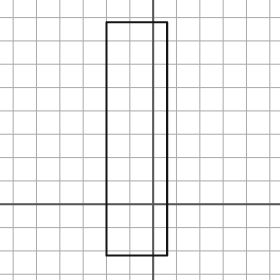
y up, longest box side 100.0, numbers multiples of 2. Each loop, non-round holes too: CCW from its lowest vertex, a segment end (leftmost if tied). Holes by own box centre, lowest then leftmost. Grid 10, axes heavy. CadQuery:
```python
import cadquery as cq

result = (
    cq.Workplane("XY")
    .moveTo(-20.0, -22.0)
    .lineTo(6.0, -22.0)
    .lineTo(6.0, 78.0)
    .lineTo(-20.0, 78.0)
    .close()
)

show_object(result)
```